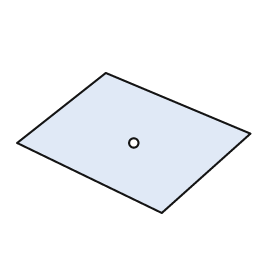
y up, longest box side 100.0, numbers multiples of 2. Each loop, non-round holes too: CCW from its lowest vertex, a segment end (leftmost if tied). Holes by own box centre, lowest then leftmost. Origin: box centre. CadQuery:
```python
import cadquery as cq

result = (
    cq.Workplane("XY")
    .moveTo(12.0, -30.0)
    .lineTo(50.0, 4.0)
    .lineTo(-12.0, 30.0)
    .lineTo(-50.0, 0.0)
    .close()
    .moveTo(0.0, 0.0)
    .circle(2.0)
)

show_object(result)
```